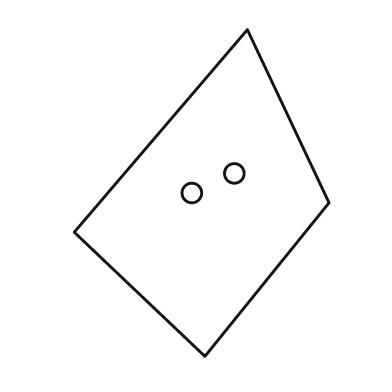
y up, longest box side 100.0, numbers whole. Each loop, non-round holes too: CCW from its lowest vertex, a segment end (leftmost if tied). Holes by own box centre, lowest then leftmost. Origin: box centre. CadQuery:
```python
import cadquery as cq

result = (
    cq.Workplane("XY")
    .moveTo(1.0, -50.0)
    .lineTo(39.0, -3.0)
    .lineTo(14.0, 50.0)
    .lineTo(-39.0, -12.0)
    .close()
    .moveTo(-3.0, 0.0)
    .circle(3.0)
    .moveTo(10.0, 6.0)
    .circle(3.0)
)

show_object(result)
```